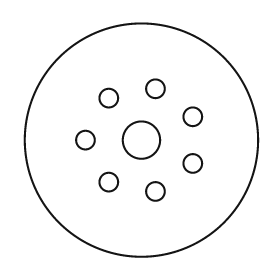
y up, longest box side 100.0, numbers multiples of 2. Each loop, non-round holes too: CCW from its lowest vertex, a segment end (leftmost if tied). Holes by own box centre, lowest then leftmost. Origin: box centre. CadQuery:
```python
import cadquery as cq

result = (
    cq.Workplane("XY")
    .moveTo(0.0, 0.0)
    .circle(50.0)
    .moveTo(6.0, -22.0)
    .circle(4.0)
    .moveTo(-14.0, -18.0)
    .circle(4.0)
    .moveTo(22.0, -10.0)
    .circle(4.0)
    .moveTo(-24.0, 0.0)
    .circle(4.0)
    .moveTo(0.0, 0.0)
    .circle(8.0)
    .moveTo(22.0, 10.0)
    .circle(4.0)
    .moveTo(-14.0, 18.0)
    .circle(4.0)
    .moveTo(6.0, 22.0)
    .circle(4.0)
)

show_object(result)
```